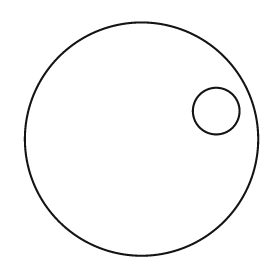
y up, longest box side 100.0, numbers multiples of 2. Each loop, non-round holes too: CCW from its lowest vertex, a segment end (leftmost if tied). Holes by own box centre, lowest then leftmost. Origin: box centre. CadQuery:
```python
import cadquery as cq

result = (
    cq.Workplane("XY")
    .moveTo(0.0, 0.0)
    .circle(50.0)
    .moveTo(32.0, 12.0)
    .circle(10.0)
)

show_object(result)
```